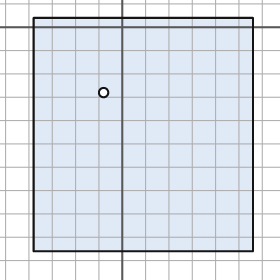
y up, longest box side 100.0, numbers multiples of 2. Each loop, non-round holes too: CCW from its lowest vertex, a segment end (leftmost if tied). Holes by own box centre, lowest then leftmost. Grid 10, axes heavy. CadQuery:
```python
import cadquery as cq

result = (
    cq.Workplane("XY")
    .moveTo(-38.0, -96.0)
    .lineTo(56.0, -96.0)
    .lineTo(56.0, 4.0)
    .lineTo(-38.0, 4.0)
    .close()
    .moveTo(-8.0, -28.0)
    .circle(2.0)
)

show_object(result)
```